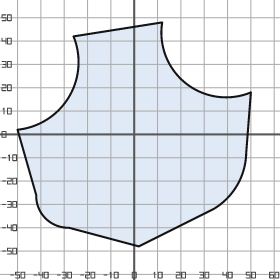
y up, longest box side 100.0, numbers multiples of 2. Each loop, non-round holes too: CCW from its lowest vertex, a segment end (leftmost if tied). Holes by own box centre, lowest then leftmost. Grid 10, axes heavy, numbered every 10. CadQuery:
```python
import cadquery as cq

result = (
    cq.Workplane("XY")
    .moveTo(2.0, -48.0)
    .lineTo(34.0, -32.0)
    .threePointArc((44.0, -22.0), (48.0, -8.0))
    .lineTo(50.0, 18.0)
    .threePointArc((22.0, 22.0), (12.0, 48.0))
    .lineTo(-26.0, 42.0)
    .threePointArc((-28.0, 16.0), (-50.0, 2.0))
    .lineTo(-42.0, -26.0)
    .threePointArc((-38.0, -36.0), (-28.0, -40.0))
    .close()
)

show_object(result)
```